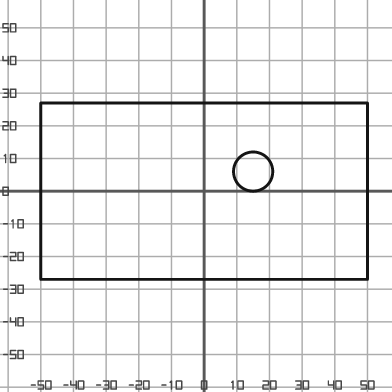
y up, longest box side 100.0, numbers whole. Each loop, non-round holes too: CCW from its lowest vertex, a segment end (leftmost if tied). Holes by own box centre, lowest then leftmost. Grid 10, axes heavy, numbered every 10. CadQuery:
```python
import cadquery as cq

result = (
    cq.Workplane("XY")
    .moveTo(-50.0, -27.0)
    .lineTo(50.0, -27.0)
    .lineTo(50.0, 27.0)
    .lineTo(-50.0, 27.0)
    .close()
    .moveTo(15.0, 6.0)
    .circle(6.0)
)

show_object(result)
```